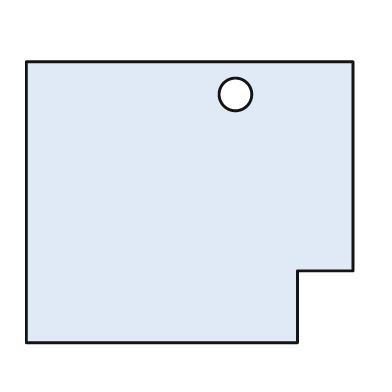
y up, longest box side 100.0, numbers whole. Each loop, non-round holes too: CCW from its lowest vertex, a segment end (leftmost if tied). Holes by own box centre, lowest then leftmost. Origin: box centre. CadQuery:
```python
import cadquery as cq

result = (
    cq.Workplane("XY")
    .moveTo(-50.0, -43.0)
    .lineTo(33.0, -43.0)
    .lineTo(33.0, -21.0)
    .lineTo(50.0, -21.0)
    .lineTo(50.0, 43.0)
    .lineTo(-50.0, 43.0)
    .close()
    .moveTo(14.0, 33.0)
    .circle(5.0)
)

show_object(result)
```